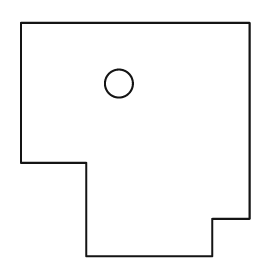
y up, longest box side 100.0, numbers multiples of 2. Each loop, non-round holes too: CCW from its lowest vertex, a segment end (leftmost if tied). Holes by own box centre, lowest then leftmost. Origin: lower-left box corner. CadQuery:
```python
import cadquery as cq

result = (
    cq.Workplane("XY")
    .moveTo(28.0, 0.0)
    .lineTo(82.0, 0.0)
    .lineTo(82.0, 16.0)
    .lineTo(98.0, 16.0)
    .lineTo(98.0, 100.0)
    .lineTo(0.0, 100.0)
    .lineTo(0.0, 40.0)
    .lineTo(28.0, 40.0)
    .close()
    .moveTo(42.0, 74.0)
    .circle(6.0)
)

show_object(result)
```